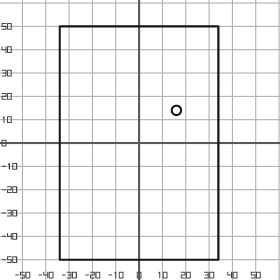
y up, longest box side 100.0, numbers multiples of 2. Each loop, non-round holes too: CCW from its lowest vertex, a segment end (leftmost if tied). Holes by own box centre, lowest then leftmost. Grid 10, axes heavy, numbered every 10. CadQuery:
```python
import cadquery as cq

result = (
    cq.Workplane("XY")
    .moveTo(-34.0, -50.0)
    .lineTo(34.0, -50.0)
    .lineTo(34.0, 50.0)
    .lineTo(-34.0, 50.0)
    .close()
    .moveTo(16.0, 14.0)
    .circle(2.0)
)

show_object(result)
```